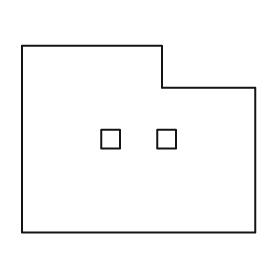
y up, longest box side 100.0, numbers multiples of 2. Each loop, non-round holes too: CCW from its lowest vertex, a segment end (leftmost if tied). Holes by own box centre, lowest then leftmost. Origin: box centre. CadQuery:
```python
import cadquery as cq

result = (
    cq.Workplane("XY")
    .moveTo(-50.0, -40.0)
    .lineTo(50.0, -40.0)
    .lineTo(50.0, 22.0)
    .lineTo(10.0, 22.0)
    .lineTo(10.0, 40.0)
    .lineTo(-50.0, 40.0)
    .close()
    .moveTo(-16.0, -4.0)
    .lineTo(-8.0, -4.0)
    .lineTo(-8.0, 4.0)
    .lineTo(-16.0, 4.0)
    .close()
    .moveTo(8.0, -4.0)
    .lineTo(16.0, -4.0)
    .lineTo(16.0, 4.0)
    .lineTo(8.0, 4.0)
    .close()
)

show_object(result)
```